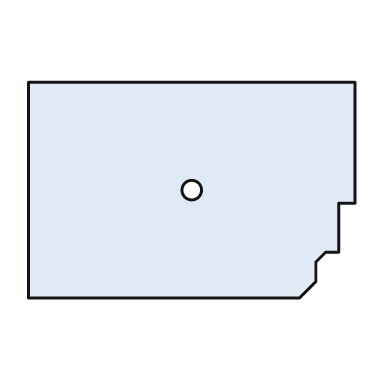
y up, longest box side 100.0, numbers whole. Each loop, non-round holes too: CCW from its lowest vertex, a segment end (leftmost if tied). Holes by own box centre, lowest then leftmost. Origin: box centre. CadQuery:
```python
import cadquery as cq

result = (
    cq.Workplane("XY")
    .moveTo(-50.0, -33.0)
    .lineTo(33.0, -33.0)
    .lineTo(38.0, -28.0)
    .lineTo(38.0, -22.0)
    .lineTo(41.0, -19.0)
    .lineTo(45.0, -19.0)
    .lineTo(45.0, -4.0)
    .lineTo(50.0, -4.0)
    .lineTo(50.0, 33.0)
    .lineTo(-50.0, 33.0)
    .close()
    .moveTo(0.0, 0.0)
    .circle(3.0)
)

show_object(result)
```